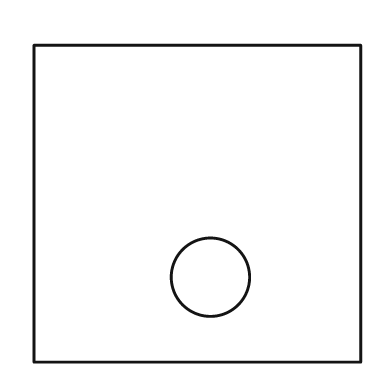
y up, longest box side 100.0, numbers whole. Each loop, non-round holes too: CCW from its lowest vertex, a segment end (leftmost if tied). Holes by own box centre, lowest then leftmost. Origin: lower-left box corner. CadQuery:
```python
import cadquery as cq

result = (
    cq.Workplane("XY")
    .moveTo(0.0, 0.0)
    .lineTo(100.0, 0.0)
    .lineTo(100.0, 97.0)
    .lineTo(0.0, 97.0)
    .close()
    .moveTo(54.0, 26.0)
    .circle(12.0)
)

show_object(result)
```